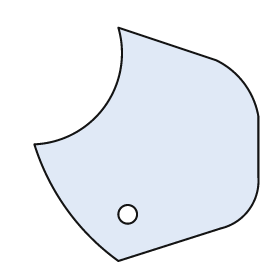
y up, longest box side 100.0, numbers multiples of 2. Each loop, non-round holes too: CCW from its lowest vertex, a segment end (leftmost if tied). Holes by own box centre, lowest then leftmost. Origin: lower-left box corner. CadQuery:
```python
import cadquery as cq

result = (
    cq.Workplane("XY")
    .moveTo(36.0, 0.0)
    .lineTo(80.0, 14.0)
    .threePointArc((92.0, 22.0), (96.0, 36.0))
    .lineTo(96.0, 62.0)
    .threePointArc((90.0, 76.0), (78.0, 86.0))
    .lineTo(36.0, 100.0)
    .threePointArc((30.0, 66.0), (0.0, 50.0))
    .threePointArc((14.0, 22.0), (36.0, 0.0))
    .close()
    .moveTo(40.0, 20.0)
    .circle(4.0)
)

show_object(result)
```